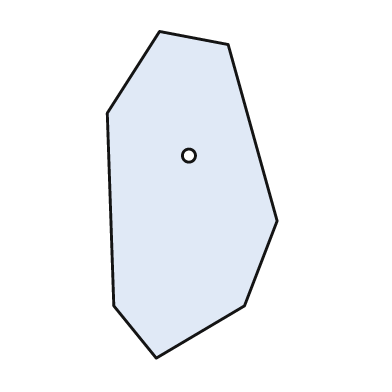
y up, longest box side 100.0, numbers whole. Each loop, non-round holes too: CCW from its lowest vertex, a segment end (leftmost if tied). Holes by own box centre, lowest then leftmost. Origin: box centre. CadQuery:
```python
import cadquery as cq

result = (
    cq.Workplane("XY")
    .moveTo(-11.0, -50.0)
    .lineTo(16.0, -34.0)
    .lineTo(26.0, -8.0)
    .lineTo(11.0, 46.0)
    .lineTo(-10.0, 50.0)
    .lineTo(-26.0, 25.0)
    .lineTo(-24.0, -34.0)
    .close()
    .moveTo(-1.0, 12.0)
    .circle(2.0)
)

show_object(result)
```